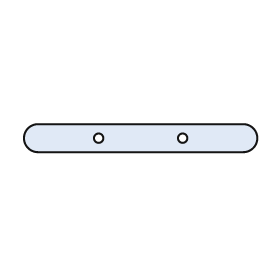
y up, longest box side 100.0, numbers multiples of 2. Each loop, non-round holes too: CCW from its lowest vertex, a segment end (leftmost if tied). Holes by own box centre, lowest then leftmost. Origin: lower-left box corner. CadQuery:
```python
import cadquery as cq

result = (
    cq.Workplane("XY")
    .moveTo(6.0, 0.0)
    .lineTo(94.0, 0.0)
    .threePointArc((100.0, 6.0), (94.0, 12.0))
    .lineTo(6.0, 12.0)
    .threePointArc((0.0, 6.0), (6.0, 0.0))
    .close()
    .moveTo(32.0, 6.0)
    .circle(2.0)
    .moveTo(68.0, 6.0)
    .circle(2.0)
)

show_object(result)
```